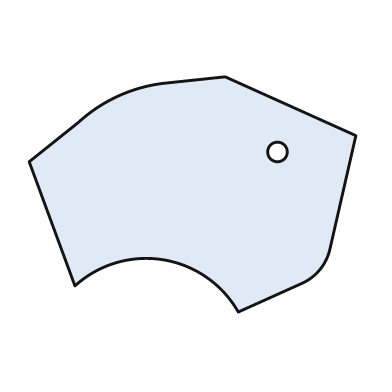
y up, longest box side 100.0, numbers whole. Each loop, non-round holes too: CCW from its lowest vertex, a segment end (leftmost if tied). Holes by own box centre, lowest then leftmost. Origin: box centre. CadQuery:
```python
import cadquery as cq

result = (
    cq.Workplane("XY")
    .moveTo(14.0, -36.0)
    .lineTo(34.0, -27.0)
    .threePointArc((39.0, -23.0), (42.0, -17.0))
    .lineTo(50.0, 18.0)
    .lineTo(10.0, 36.0)
    .lineTo(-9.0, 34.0)
    .threePointArc((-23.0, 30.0), (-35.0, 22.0))
    .lineTo(-50.0, 10.0)
    .lineTo(-36.0, -28.0)
    .threePointArc((-9.0, -20.0), (14.0, -36.0))
    .close()
    .moveTo(26.0, 13.0)
    .circle(3.0)
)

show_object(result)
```